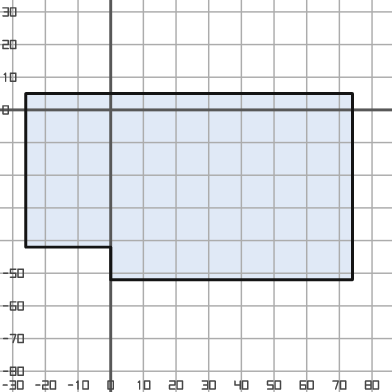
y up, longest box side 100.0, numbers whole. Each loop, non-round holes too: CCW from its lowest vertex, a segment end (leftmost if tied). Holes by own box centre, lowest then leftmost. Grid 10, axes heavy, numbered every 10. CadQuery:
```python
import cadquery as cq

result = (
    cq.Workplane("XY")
    .moveTo(0.0, -52.0)
    .lineTo(74.0, -52.0)
    .lineTo(74.0, 5.0)
    .lineTo(-26.0, 5.0)
    .lineTo(-26.0, -42.0)
    .lineTo(0.0, -42.0)
    .close()
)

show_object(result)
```